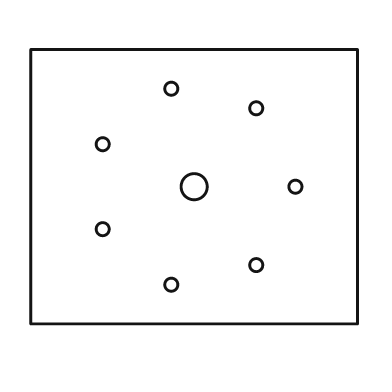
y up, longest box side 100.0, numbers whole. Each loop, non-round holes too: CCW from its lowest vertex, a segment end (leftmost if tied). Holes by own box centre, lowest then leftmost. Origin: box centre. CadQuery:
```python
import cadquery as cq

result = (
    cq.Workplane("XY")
    .moveTo(-50.0, -42.0)
    .lineTo(50.0, -42.0)
    .lineTo(50.0, 42.0)
    .lineTo(-50.0, 42.0)
    .close()
    .moveTo(-7.0, -30.0)
    .circle(2.0)
    .moveTo(19.0, -24.0)
    .circle(2.0)
    .moveTo(-28.0, -13.0)
    .circle(2.0)
    .moveTo(0.0, 0.0)
    .circle(4.0)
    .moveTo(31.0, 0.0)
    .circle(2.0)
    .moveTo(-28.0, 13.0)
    .circle(2.0)
    .moveTo(19.0, 24.0)
    .circle(2.0)
    .moveTo(-7.0, 30.0)
    .circle(2.0)
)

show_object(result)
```